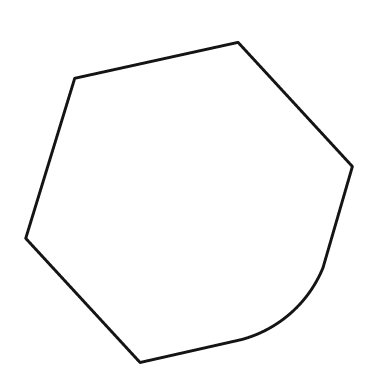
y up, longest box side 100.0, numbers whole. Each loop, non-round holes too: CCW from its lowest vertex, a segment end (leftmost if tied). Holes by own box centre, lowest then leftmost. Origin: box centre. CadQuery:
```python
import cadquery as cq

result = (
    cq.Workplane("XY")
    .moveTo(-15.0, -49.0)
    .lineTo(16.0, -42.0)
    .threePointArc((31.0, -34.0), (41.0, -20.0))
    .lineTo(50.0, 11.0)
    .lineTo(15.0, 49.0)
    .lineTo(-35.0, 38.0)
    .lineTo(-50.0, -11.0)
    .close()
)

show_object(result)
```